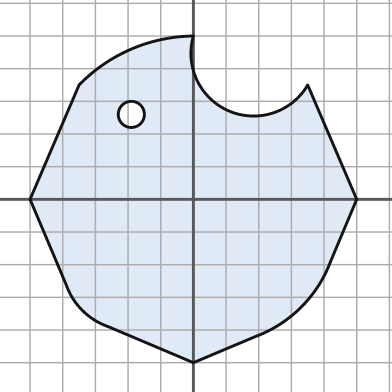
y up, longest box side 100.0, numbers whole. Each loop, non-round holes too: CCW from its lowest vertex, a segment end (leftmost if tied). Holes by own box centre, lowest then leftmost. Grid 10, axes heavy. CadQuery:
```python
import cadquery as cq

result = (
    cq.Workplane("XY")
    .moveTo(0.0, -50.0)
    .lineTo(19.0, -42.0)
    .threePointArc((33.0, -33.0), (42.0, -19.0))
    .lineTo(50.0, 0.0)
    .lineTo(35.0, 35.0)
    .threePointArc((11.0, 27.0), (0.0, 50.0))
    .threePointArc((-19.0, 46.0), (-35.0, 35.0))
    .lineTo(-50.0, 0.0)
    .lineTo(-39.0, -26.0)
    .threePointArc((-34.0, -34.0), (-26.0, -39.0))
    .close()
    .moveTo(-19.0, 26.0)
    .circle(4.0)
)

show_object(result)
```